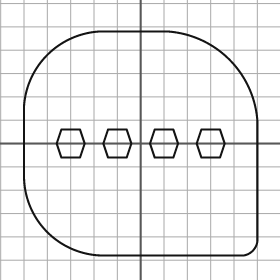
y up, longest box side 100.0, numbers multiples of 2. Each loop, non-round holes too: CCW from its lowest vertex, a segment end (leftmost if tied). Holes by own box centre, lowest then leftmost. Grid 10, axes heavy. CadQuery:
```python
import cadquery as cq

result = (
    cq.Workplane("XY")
    .moveTo(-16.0, -48.0)
    .lineTo(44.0, -48.0)
    .threePointArc((48.0, -46.0), (50.0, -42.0))
    .lineTo(50.0, 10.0)
    .threePointArc((38.0, 36.0), (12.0, 48.0))
    .lineTo(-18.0, 48.0)
    .threePointArc((-40.0, 38.0), (-50.0, 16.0))
    .lineTo(-50.0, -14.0)
    .threePointArc((-40.0, -38.0), (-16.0, -48.0))
    .close()
    .moveTo(-34.0, -6.0)
    .lineTo(-26.0, -6.0)
    .lineTo(-24.0, 0.0)
    .lineTo(-26.0, 6.0)
    .lineTo(-34.0, 6.0)
    .lineTo(-36.0, 0.0)
    .close()
    .moveTo(-14.0, -6.0)
    .lineTo(-6.0, -6.0)
    .lineTo(-4.0, 0.0)
    .lineTo(-6.0, 6.0)
    .lineTo(-14.0, 6.0)
    .lineTo(-16.0, 0.0)
    .close()
    .moveTo(6.0, -6.0)
    .lineTo(14.0, -6.0)
    .lineTo(16.0, 0.0)
    .lineTo(14.0, 6.0)
    .lineTo(6.0, 6.0)
    .lineTo(4.0, 0.0)
    .close()
    .moveTo(26.0, -6.0)
    .lineTo(34.0, -6.0)
    .lineTo(36.0, 0.0)
    .lineTo(34.0, 6.0)
    .lineTo(26.0, 6.0)
    .lineTo(24.0, 0.0)
    .close()
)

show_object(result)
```